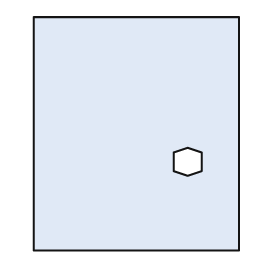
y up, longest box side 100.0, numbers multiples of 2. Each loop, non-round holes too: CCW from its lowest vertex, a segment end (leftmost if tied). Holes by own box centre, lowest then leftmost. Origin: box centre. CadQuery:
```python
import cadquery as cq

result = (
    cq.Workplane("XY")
    .moveTo(-44.0, -50.0)
    .lineTo(44.0, -50.0)
    .lineTo(44.0, 50.0)
    .lineTo(-44.0, 50.0)
    .close()
    .moveTo(22.0, -18.0)
    .lineTo(28.0, -16.0)
    .lineTo(28.0, -8.0)
    .lineTo(22.0, -6.0)
    .lineTo(16.0, -8.0)
    .lineTo(16.0, -16.0)
    .close()
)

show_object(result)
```